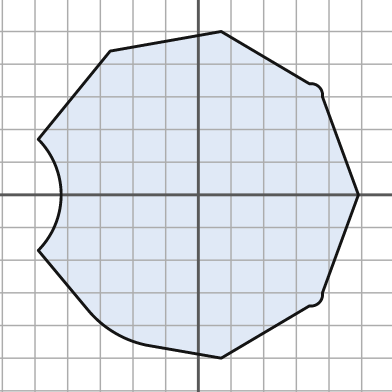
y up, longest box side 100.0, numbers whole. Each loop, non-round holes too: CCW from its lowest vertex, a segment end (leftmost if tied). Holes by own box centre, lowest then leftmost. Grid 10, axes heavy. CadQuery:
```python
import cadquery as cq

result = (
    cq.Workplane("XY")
    .moveTo(7.0, -50.0)
    .lineTo(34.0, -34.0)
    .threePointArc((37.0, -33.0), (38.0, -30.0))
    .lineTo(49.0, 0.0)
    .lineTo(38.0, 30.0)
    .threePointArc((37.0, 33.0), (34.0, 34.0))
    .lineTo(7.0, 50.0)
    .lineTo(-27.0, 44.0)
    .lineTo(-49.0, 17.0)
    .threePointArc((-42.0, 0.0), (-49.0, -17.0))
    .lineTo(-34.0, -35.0)
    .threePointArc((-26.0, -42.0), (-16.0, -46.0))
    .close()
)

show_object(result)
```